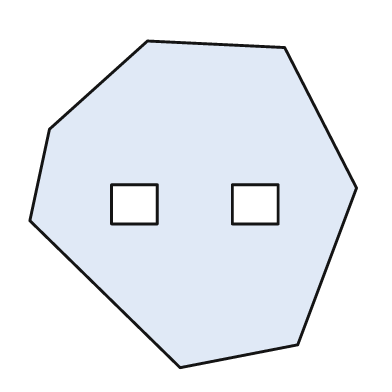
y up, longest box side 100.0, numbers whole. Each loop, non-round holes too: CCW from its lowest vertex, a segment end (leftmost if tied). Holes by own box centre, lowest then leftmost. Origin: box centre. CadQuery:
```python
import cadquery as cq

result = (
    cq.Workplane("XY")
    .moveTo(-4.0, -50.0)
    .lineTo(32.0, -43.0)
    .lineTo(50.0, 5.0)
    .lineTo(28.0, 48.0)
    .lineTo(-14.0, 50.0)
    .lineTo(-44.0, 23.0)
    .lineTo(-50.0, -5.0)
    .close()
    .moveTo(-25.0, -6.0)
    .lineTo(-11.0, -6.0)
    .lineTo(-11.0, 6.0)
    .lineTo(-25.0, 6.0)
    .close()
    .moveTo(12.0, -6.0)
    .lineTo(26.0, -6.0)
    .lineTo(26.0, 6.0)
    .lineTo(12.0, 6.0)
    .close()
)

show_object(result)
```